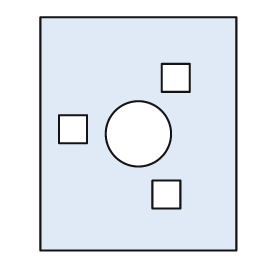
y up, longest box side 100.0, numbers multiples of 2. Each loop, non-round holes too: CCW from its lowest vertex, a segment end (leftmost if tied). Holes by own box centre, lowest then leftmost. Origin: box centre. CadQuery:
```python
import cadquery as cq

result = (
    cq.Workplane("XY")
    .moveTo(-42.0, -50.0)
    .lineTo(42.0, -50.0)
    .lineTo(42.0, 50.0)
    .lineTo(-42.0, 50.0)
    .close()
    .moveTo(6.0, -32.0)
    .lineTo(18.0, -32.0)
    .lineTo(18.0, -20.0)
    .lineTo(6.0, -20.0)
    .close()
    .moveTo(0.0, 0.0)
    .circle(14.0)
    .moveTo(-34.0, -4.0)
    .lineTo(-22.0, -4.0)
    .lineTo(-22.0, 8.0)
    .lineTo(-34.0, 8.0)
    .close()
    .moveTo(10.0, 18.0)
    .lineTo(22.0, 18.0)
    .lineTo(22.0, 30.0)
    .lineTo(10.0, 30.0)
    .close()
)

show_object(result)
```